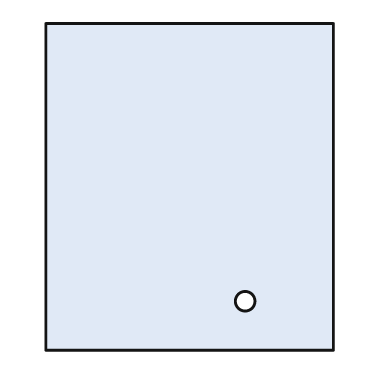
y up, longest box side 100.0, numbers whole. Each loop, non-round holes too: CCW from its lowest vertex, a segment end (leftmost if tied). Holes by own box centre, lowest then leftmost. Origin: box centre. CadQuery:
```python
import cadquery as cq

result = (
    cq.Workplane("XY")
    .moveTo(-44.0, -50.0)
    .lineTo(44.0, -50.0)
    .lineTo(44.0, 50.0)
    .lineTo(-44.0, 50.0)
    .close()
    .moveTo(17.0, -35.0)
    .circle(3.0)
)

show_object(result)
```